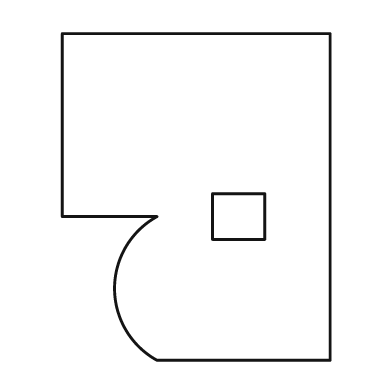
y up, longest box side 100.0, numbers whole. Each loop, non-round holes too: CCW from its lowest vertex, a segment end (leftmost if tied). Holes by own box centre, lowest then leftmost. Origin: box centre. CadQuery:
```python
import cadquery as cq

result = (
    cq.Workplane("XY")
    .moveTo(-12.0, -50.0)
    .lineTo(41.0, -50.0)
    .lineTo(41.0, 50.0)
    .lineTo(-41.0, 50.0)
    .lineTo(-41.0, -6.0)
    .lineTo(-12.0, -6.0)
    .threePointArc((-25.0, -28.0), (-12.0, -50.0))
    .close()
    .moveTo(5.0, -13.0)
    .lineTo(21.0, -13.0)
    .lineTo(21.0, 1.0)
    .lineTo(5.0, 1.0)
    .close()
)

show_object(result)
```